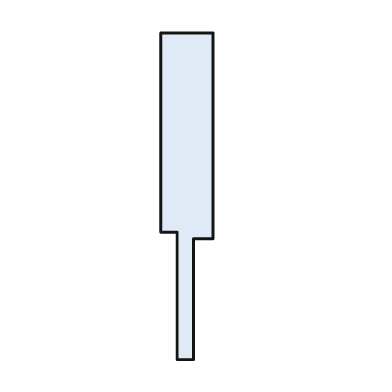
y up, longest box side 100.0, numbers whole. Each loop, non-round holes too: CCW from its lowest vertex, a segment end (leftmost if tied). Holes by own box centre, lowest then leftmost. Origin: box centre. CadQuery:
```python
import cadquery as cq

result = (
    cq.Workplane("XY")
    .moveTo(-3.0, -50.0)
    .lineTo(2.0, -50.0)
    .lineTo(2.0, -13.0)
    .lineTo(8.0, -13.0)
    .lineTo(8.0, 50.0)
    .lineTo(-8.0, 50.0)
    .lineTo(-8.0, -11.0)
    .lineTo(-3.0, -11.0)
    .close()
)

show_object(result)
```